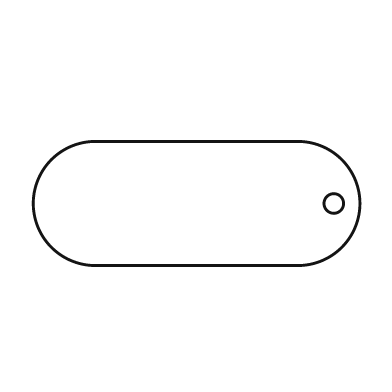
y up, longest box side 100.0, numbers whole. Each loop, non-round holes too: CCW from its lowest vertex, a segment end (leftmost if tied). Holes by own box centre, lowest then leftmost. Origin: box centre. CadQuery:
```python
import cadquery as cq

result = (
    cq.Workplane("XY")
    .moveTo(-31.0, -19.0)
    .lineTo(31.0, -19.0)
    .threePointArc((50.0, 0.0), (31.0, 19.0))
    .lineTo(-31.0, 19.0)
    .threePointArc((-50.0, 0.0), (-31.0, -19.0))
    .close()
    .moveTo(42.0, 0.0)
    .circle(3.0)
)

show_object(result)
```